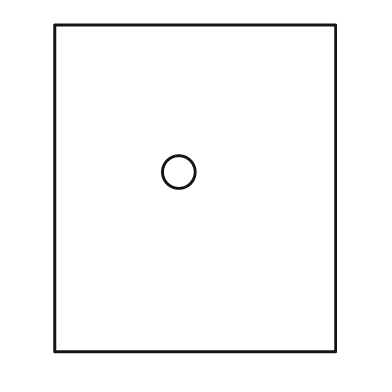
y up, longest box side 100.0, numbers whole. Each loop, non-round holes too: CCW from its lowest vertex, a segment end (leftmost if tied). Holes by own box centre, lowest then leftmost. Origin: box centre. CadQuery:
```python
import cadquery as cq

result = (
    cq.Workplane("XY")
    .moveTo(-43.0, -50.0)
    .lineTo(43.0, -50.0)
    .lineTo(43.0, 50.0)
    .lineTo(-43.0, 50.0)
    .close()
    .moveTo(-5.0, 5.0)
    .circle(5.0)
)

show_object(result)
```